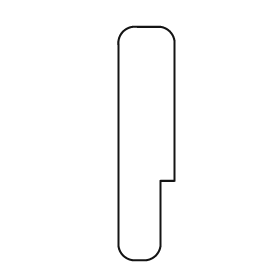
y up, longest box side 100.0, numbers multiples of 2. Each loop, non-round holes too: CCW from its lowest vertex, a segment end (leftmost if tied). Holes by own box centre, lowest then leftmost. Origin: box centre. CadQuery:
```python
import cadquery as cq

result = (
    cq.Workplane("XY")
    .moveTo(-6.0, -50.0)
    .lineTo(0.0, -50.0)
    .threePointArc((4.0, -48.0), (6.0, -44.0))
    .lineTo(6.0, -16.0)
    .lineTo(12.0, -16.0)
    .lineTo(12.0, 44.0)
    .threePointArc((10.0, 48.0), (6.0, 50.0))
    .lineTo(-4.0, 50.0)
    .threePointArc((-10.0, 48.0), (-12.0, 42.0))
    .lineTo(-12.0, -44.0)
    .threePointArc((-10.0, -48.0), (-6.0, -50.0))
    .close()
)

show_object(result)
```